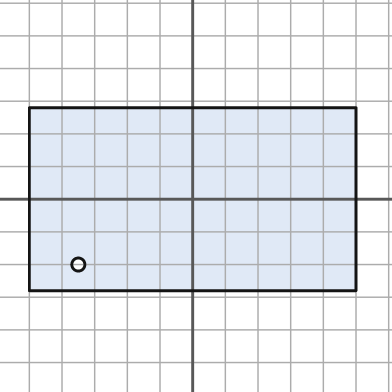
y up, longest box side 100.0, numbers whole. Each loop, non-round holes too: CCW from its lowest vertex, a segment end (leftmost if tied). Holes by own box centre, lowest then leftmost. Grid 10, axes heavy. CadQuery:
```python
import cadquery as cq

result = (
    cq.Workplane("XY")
    .moveTo(-50.0, -28.0)
    .lineTo(50.0, -28.0)
    .lineTo(50.0, 28.0)
    .lineTo(-50.0, 28.0)
    .close()
    .moveTo(-35.0, -20.0)
    .circle(2.0)
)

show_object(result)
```